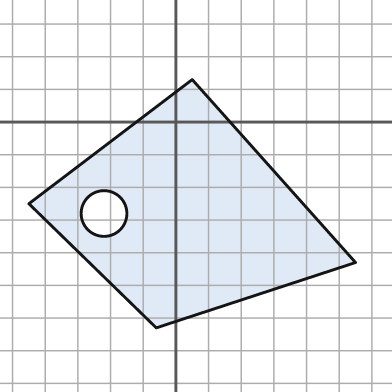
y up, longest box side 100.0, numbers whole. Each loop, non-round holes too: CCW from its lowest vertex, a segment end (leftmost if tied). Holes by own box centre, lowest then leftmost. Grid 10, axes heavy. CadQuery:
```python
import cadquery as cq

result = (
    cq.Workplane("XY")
    .moveTo(-6.0, -63.0)
    .lineTo(55.0, -43.0)
    .lineTo(5.0, 13.0)
    .lineTo(-45.0, -25.0)
    .close()
    .moveTo(-22.0, -28.0)
    .circle(7.0)
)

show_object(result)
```